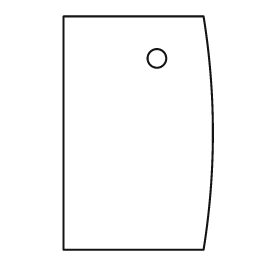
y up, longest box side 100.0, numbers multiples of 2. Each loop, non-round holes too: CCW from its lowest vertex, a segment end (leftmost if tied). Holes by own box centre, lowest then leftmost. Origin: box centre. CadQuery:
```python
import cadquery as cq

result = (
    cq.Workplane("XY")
    .moveTo(-32.0, -50.0)
    .lineTo(28.0, -50.0)
    .threePointArc((32.0, 0.0), (28.0, 50.0))
    .lineTo(-32.0, 50.0)
    .close()
    .moveTo(8.0, 32.0)
    .circle(4.0)
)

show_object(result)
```